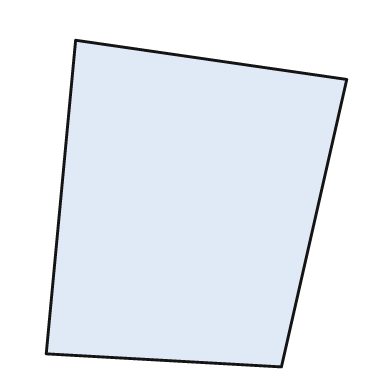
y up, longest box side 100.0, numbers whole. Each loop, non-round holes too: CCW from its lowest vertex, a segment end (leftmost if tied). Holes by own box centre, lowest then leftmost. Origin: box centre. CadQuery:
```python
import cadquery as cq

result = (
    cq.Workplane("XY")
    .moveTo(26.0, -50.0)
    .lineTo(46.0, 38.0)
    .lineTo(-37.0, 50.0)
    .lineTo(-46.0, -46.0)
    .close()
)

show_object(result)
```